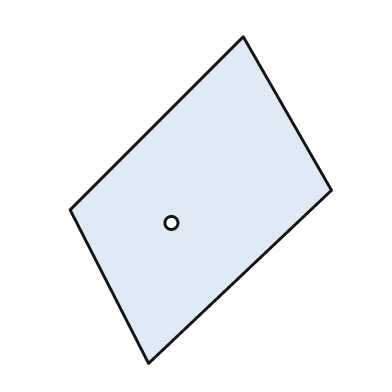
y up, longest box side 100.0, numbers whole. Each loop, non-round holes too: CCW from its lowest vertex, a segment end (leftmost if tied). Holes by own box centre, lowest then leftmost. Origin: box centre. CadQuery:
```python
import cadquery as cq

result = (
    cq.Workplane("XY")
    .moveTo(-16.0, -50.0)
    .lineTo(40.0, 3.0)
    .lineTo(13.0, 50.0)
    .lineTo(-40.0, -3.0)
    .close()
    .moveTo(-9.0, -7.0)
    .circle(2.0)
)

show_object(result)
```